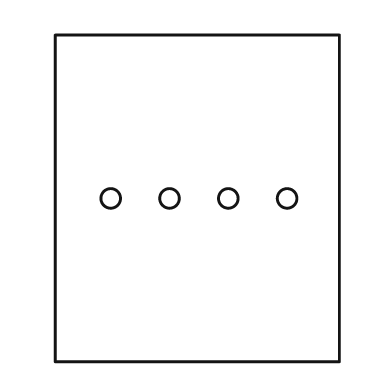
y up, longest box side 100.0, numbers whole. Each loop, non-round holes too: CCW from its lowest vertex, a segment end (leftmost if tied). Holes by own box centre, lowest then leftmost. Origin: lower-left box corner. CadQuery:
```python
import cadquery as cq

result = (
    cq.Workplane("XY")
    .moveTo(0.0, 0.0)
    .lineTo(87.0, 0.0)
    .lineTo(87.0, 100.0)
    .lineTo(0.0, 100.0)
    .close()
    .moveTo(17.0, 50.0)
    .circle(3.0)
    .moveTo(35.0, 50.0)
    .circle(3.0)
    .moveTo(53.0, 50.0)
    .circle(3.0)
    .moveTo(71.0, 50.0)
    .circle(3.0)
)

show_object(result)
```